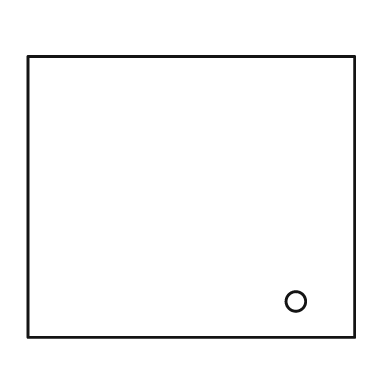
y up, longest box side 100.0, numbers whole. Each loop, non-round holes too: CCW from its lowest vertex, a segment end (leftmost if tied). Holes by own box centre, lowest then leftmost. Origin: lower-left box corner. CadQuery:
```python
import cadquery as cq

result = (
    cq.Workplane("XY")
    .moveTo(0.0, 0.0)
    .lineTo(100.0, 0.0)
    .lineTo(100.0, 86.0)
    .lineTo(0.0, 86.0)
    .close()
    .moveTo(82.0, 11.0)
    .circle(3.0)
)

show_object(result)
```